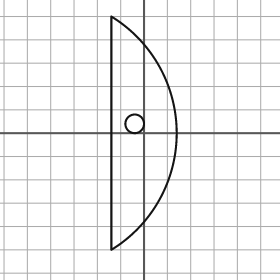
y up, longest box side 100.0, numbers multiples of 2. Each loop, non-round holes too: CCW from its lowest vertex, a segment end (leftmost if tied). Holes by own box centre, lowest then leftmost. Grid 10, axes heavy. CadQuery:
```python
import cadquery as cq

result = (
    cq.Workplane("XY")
    .moveTo(-14.0, -50.0)
    .threePointArc((14.0, 0.0), (-14.0, 50.0))
    .close()
    .moveTo(-4.0, 4.0)
    .circle(4.0)
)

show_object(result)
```